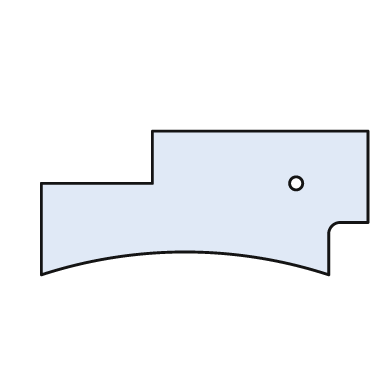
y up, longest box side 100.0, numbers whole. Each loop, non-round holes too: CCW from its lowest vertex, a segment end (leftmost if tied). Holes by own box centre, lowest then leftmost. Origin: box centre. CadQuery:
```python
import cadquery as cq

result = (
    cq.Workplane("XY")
    .moveTo(-50.0, -22.0)
    .threePointArc((-6.0, -15.0), (38.0, -22.0))
    .lineTo(38.0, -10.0)
    .threePointArc((39.0, -7.0), (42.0, -6.0))
    .lineTo(50.0, -6.0)
    .lineTo(50.0, 22.0)
    .lineTo(-16.0, 22.0)
    .lineTo(-16.0, 6.0)
    .lineTo(-50.0, 6.0)
    .close()
    .moveTo(28.0, 6.0)
    .circle(2.0)
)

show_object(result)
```